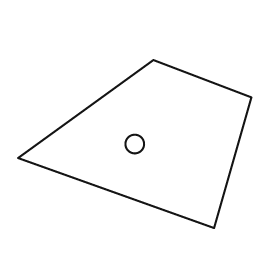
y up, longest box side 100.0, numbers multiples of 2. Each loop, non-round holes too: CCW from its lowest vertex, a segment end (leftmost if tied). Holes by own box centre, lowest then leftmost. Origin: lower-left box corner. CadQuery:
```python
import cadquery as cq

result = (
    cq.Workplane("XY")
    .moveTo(84.0, 0.0)
    .lineTo(100.0, 56.0)
    .lineTo(58.0, 72.0)
    .lineTo(0.0, 30.0)
    .close()
    .moveTo(50.0, 36.0)
    .circle(4.0)
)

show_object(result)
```